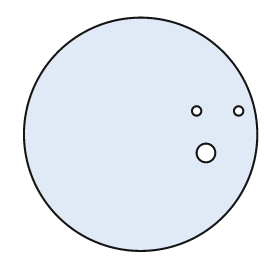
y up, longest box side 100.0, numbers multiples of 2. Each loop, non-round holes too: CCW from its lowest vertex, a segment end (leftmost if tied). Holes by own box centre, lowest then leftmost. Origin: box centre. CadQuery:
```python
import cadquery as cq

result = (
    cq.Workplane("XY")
    .moveTo(0.0, 0.0)
    .circle(50.0)
    .moveTo(28.0, -8.0)
    .circle(4.0)
    .moveTo(24.0, 10.0)
    .circle(2.0)
    .moveTo(42.0, 10.0)
    .circle(2.0)
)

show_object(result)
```